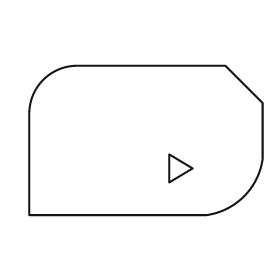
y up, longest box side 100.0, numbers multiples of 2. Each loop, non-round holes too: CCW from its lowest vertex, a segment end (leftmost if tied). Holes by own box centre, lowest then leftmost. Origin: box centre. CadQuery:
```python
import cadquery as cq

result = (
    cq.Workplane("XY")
    .moveTo(-50.0, -32.0)
    .lineTo(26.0, -32.0)
    .threePointArc((42.0, -24.0), (50.0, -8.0))
    .lineTo(50.0, 16.0)
    .lineTo(34.0, 32.0)
    .lineTo(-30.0, 32.0)
    .threePointArc((-44.0, 26.0), (-50.0, 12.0))
    .close()
    .moveTo(10.0, -18.0)
    .lineTo(20.0, -12.0)
    .lineTo(10.0, -6.0)
    .close()
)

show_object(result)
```